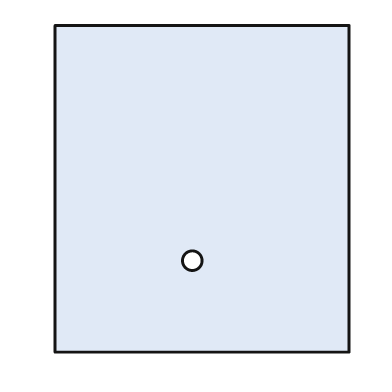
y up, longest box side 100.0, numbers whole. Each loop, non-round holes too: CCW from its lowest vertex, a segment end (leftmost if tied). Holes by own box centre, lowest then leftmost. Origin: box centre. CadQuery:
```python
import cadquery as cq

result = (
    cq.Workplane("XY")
    .moveTo(-45.0, -50.0)
    .lineTo(45.0, -50.0)
    .lineTo(45.0, 50.0)
    .lineTo(-45.0, 50.0)
    .close()
    .moveTo(-3.0, -22.0)
    .circle(3.0)
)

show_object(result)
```